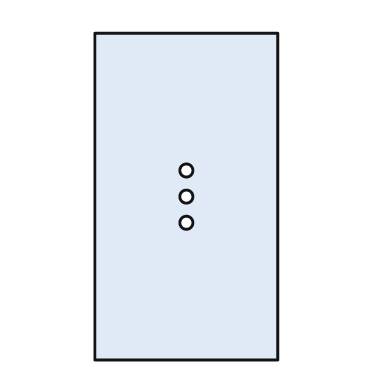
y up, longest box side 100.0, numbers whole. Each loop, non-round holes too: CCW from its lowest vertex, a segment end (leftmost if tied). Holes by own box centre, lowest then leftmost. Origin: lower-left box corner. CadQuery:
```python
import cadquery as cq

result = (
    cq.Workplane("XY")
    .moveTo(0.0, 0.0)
    .lineTo(56.0, 0.0)
    .lineTo(56.0, 100.0)
    .lineTo(0.0, 100.0)
    .close()
    .moveTo(28.0, 42.0)
    .circle(2.0)
    .moveTo(28.0, 50.0)
    .circle(2.0)
    .moveTo(28.0, 58.0)
    .circle(2.0)
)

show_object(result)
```